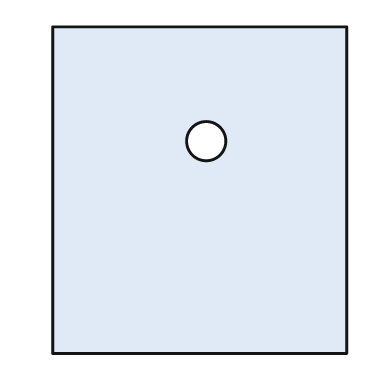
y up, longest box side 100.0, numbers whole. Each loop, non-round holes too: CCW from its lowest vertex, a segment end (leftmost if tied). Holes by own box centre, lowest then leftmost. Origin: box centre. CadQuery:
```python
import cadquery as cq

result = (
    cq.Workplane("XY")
    .moveTo(-45.0, -50.0)
    .lineTo(45.0, -50.0)
    .lineTo(45.0, 50.0)
    .lineTo(-45.0, 50.0)
    .close()
    .moveTo(2.0, 15.0)
    .circle(6.0)
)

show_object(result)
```